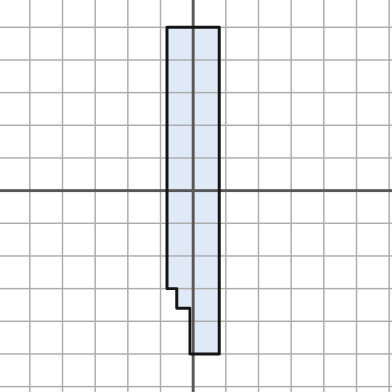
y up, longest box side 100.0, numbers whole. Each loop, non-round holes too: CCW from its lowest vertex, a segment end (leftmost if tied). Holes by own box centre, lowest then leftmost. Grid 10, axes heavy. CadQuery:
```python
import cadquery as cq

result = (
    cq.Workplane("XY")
    .moveTo(-1.0, -50.0)
    .lineTo(8.0, -50.0)
    .lineTo(8.0, 50.0)
    .lineTo(-8.0, 50.0)
    .lineTo(-8.0, -30.0)
    .lineTo(-5.0, -30.0)
    .lineTo(-5.0, -36.0)
    .lineTo(-1.0, -36.0)
    .close()
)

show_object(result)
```